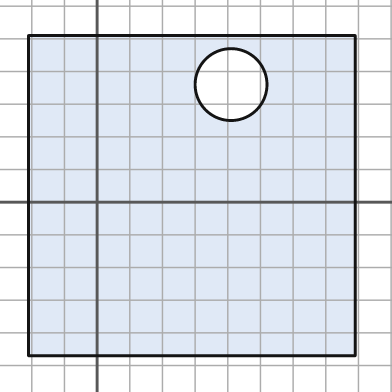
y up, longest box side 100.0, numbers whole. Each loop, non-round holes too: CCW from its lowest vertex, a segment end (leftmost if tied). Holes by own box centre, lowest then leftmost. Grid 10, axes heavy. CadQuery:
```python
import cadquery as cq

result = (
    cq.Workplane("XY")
    .moveTo(-21.0, -47.0)
    .lineTo(79.0, -47.0)
    .lineTo(79.0, 51.0)
    .lineTo(-21.0, 51.0)
    .close()
    .moveTo(41.0, 36.0)
    .circle(11.0)
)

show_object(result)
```